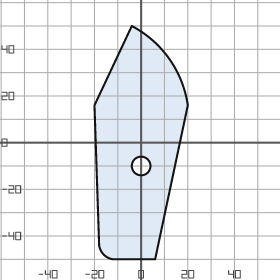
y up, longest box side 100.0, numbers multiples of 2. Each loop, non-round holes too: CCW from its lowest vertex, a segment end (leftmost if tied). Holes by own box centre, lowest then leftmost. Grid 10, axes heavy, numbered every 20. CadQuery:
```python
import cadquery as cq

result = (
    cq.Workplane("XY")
    .moveTo(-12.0, -50.0)
    .lineTo(6.0, -50.0)
    .lineTo(20.0, 16.0)
    .threePointArc((12.0, 36.0), (-4.0, 50.0))
    .lineTo(-20.0, 16.0)
    .lineTo(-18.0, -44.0)
    .threePointArc((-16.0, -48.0), (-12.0, -50.0))
    .close()
    .moveTo(0.0, -10.0)
    .circle(4.0)
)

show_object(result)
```